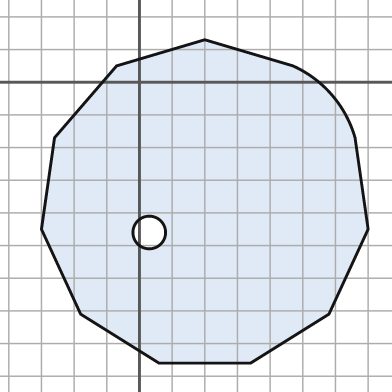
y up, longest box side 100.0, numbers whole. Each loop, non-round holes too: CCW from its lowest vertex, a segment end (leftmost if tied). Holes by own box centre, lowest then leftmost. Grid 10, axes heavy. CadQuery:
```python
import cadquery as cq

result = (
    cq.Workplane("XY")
    .moveTo(6.0, -86.0)
    .lineTo(34.0, -86.0)
    .lineTo(58.0, -71.0)
    .lineTo(70.0, -45.0)
    .lineTo(66.0, -17.0)
    .threePointArc((59.0, -4.0), (47.0, 5.0))
    .lineTo(20.0, 13.0)
    .lineTo(-7.0, 5.0)
    .lineTo(-26.0, -17.0)
    .lineTo(-30.0, -45.0)
    .lineTo(-18.0, -71.0)
    .close()
    .moveTo(3.0, -46.0)
    .circle(5.0)
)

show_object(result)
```